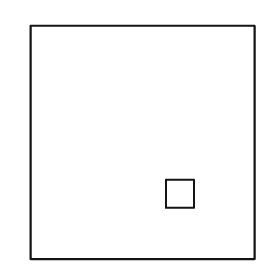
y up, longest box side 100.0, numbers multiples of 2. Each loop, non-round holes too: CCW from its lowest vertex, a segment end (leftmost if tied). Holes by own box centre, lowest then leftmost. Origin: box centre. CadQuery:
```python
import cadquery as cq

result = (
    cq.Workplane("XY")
    .moveTo(-48.0, -50.0)
    .lineTo(48.0, -50.0)
    .lineTo(48.0, 50.0)
    .lineTo(-48.0, 50.0)
    .close()
    .moveTo(10.0, -28.0)
    .lineTo(22.0, -28.0)
    .lineTo(22.0, -16.0)
    .lineTo(10.0, -16.0)
    .close()
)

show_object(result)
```